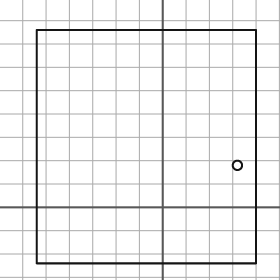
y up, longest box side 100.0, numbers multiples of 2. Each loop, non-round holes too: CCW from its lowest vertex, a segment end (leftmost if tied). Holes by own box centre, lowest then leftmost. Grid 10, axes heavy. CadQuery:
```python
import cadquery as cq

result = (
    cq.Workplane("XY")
    .moveTo(-54.0, -24.0)
    .lineTo(40.0, -24.0)
    .lineTo(40.0, 76.0)
    .lineTo(-54.0, 76.0)
    .close()
    .moveTo(32.0, 18.0)
    .circle(2.0)
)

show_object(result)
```